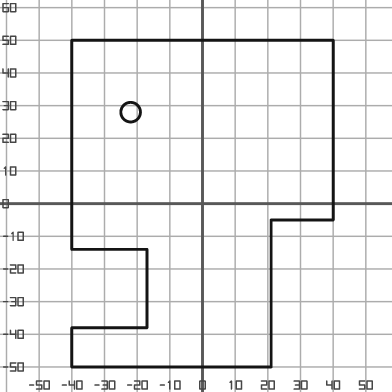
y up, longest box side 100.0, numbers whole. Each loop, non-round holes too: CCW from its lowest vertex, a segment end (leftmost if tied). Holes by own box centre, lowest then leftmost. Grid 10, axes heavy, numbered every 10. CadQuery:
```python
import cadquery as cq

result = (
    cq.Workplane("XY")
    .moveTo(-40.0, -50.0)
    .lineTo(21.0, -50.0)
    .lineTo(21.0, -5.0)
    .lineTo(40.0, -5.0)
    .lineTo(40.0, 50.0)
    .lineTo(-40.0, 50.0)
    .lineTo(-40.0, -14.0)
    .lineTo(-17.0, -14.0)
    .lineTo(-17.0, -38.0)
    .lineTo(-40.0, -38.0)
    .close()
    .moveTo(-22.0, 28.0)
    .circle(3.0)
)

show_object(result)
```